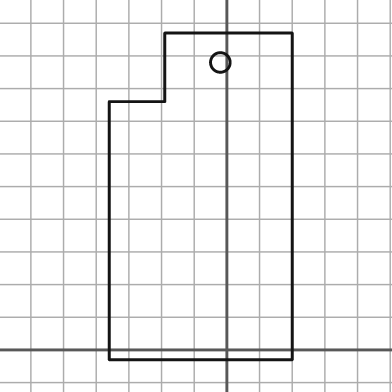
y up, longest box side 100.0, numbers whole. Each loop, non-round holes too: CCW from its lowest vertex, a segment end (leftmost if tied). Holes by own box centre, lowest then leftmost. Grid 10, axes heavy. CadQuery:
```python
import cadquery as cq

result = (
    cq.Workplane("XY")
    .moveTo(-36.0, -3.0)
    .lineTo(20.0, -3.0)
    .lineTo(20.0, 97.0)
    .lineTo(-19.0, 97.0)
    .lineTo(-19.0, 76.0)
    .lineTo(-36.0, 76.0)
    .close()
    .moveTo(-2.0, 88.0)
    .circle(3.0)
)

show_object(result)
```